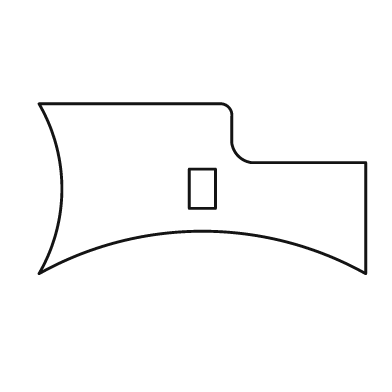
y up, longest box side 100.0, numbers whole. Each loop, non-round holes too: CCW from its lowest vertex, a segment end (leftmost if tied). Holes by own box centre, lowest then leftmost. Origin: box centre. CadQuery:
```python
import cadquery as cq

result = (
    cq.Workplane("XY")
    .moveTo(-50.0, -26.0)
    .threePointArc((0.0, -13.0), (50.0, -26.0))
    .lineTo(50.0, 8.0)
    .lineTo(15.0, 8.0)
    .threePointArc((11.0, 10.0), (9.0, 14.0))
    .lineTo(9.0, 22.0)
    .threePointArc((8.0, 25.0), (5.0, 26.0))
    .lineTo(-50.0, 26.0)
    .threePointArc((-43.0, 0.0), (-50.0, -26.0))
    .close()
    .moveTo(-4.0, -6.0)
    .lineTo(4.0, -6.0)
    .lineTo(4.0, 6.0)
    .lineTo(-4.0, 6.0)
    .close()
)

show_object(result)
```